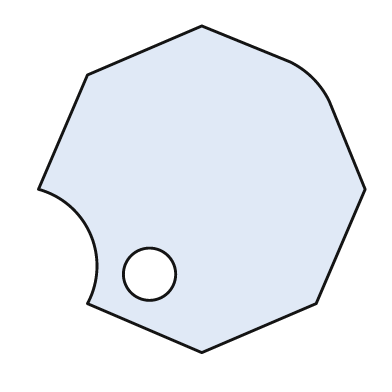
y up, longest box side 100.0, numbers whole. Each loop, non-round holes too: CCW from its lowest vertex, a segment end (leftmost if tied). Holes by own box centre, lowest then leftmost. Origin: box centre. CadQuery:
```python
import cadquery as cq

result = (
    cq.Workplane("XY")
    .moveTo(0.0, -50.0)
    .lineTo(35.0, -35.0)
    .lineTo(50.0, 0.0)
    .lineTo(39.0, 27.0)
    .threePointArc((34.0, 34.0), (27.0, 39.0))
    .lineTo(0.0, 50.0)
    .lineTo(-35.0, 35.0)
    .lineTo(-50.0, 0.0)
    .threePointArc((-34.0, -14.0), (-35.0, -35.0))
    .close()
    .moveTo(-16.0, -26.0)
    .circle(8.0)
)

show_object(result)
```